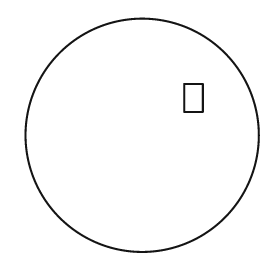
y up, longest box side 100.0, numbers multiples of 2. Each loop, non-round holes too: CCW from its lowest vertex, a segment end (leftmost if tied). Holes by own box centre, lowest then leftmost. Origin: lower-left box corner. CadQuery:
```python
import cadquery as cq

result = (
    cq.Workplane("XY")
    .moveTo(50.0, 50.0)
    .circle(50.0)
    .moveTo(68.0, 60.0)
    .lineTo(76.0, 60.0)
    .lineTo(76.0, 72.0)
    .lineTo(68.0, 72.0)
    .close()
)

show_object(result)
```